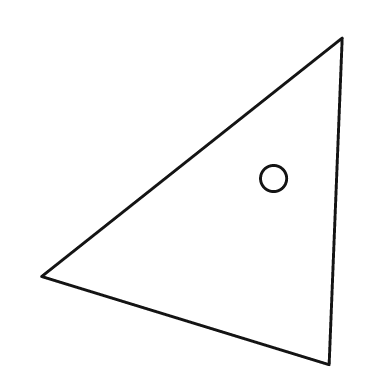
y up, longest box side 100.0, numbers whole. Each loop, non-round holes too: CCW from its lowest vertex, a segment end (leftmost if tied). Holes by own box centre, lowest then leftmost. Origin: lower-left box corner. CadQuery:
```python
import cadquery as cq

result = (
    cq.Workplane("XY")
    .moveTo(88.0, 0.0)
    .lineTo(92.0, 100.0)
    .lineTo(0.0, 27.0)
    .close()
    .moveTo(71.0, 57.0)
    .circle(4.0)
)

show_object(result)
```